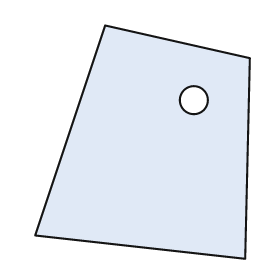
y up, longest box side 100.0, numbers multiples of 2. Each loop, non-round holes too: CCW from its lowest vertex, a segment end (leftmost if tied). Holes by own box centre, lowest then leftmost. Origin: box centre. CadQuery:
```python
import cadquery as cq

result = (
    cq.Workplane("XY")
    .moveTo(44.0, -50.0)
    .lineTo(46.0, 36.0)
    .lineTo(-16.0, 50.0)
    .lineTo(-46.0, -40.0)
    .close()
    .moveTo(22.0, 18.0)
    .circle(6.0)
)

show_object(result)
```